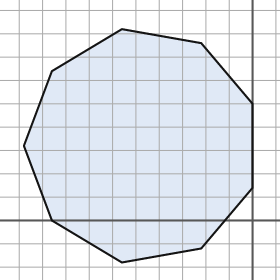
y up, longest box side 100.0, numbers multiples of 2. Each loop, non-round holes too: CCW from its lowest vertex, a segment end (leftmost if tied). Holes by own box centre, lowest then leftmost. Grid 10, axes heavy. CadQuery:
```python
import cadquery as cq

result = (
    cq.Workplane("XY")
    .moveTo(-56.0, -18.0)
    .lineTo(-22.0, -12.0)
    .lineTo(0.0, 14.0)
    .lineTo(0.0, 50.0)
    .lineTo(-22.0, 76.0)
    .lineTo(-56.0, 82.0)
    .lineTo(-86.0, 64.0)
    .lineTo(-98.0, 32.0)
    .lineTo(-86.0, 0.0)
    .close()
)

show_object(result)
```